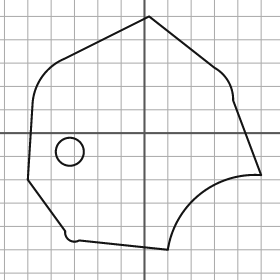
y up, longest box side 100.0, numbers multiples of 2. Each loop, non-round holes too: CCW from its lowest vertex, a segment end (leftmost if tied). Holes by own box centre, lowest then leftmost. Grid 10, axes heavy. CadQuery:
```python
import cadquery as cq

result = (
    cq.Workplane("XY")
    .moveTo(10.0, -50.0)
    .threePointArc((24.0, -26.0), (50.0, -18.0))
    .lineTo(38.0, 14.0)
    .threePointArc((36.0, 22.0), (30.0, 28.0))
    .lineTo(2.0, 50.0)
    .lineTo(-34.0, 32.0)
    .threePointArc((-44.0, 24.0), (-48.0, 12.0))
    .lineTo(-50.0, -20.0)
    .lineTo(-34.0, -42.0)
    .threePointArc((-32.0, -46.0), (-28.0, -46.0))
    .close()
    .moveTo(-32.0, -8.0)
    .circle(6.0)
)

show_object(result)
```